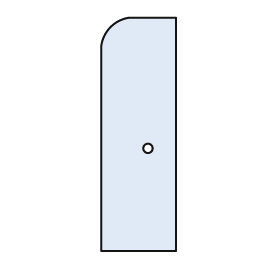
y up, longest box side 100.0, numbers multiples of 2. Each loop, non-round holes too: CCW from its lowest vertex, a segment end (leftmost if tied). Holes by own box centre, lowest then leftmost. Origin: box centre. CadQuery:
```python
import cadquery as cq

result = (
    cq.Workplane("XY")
    .moveTo(-16.0, -50.0)
    .lineTo(16.0, -50.0)
    .lineTo(16.0, 50.0)
    .lineTo(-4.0, 50.0)
    .threePointArc((-12.0, 46.0), (-16.0, 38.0))
    .close()
    .moveTo(4.0, -6.0)
    .circle(2.0)
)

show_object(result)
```